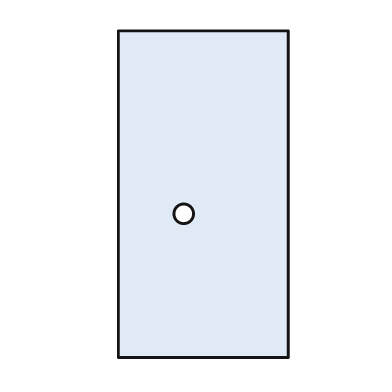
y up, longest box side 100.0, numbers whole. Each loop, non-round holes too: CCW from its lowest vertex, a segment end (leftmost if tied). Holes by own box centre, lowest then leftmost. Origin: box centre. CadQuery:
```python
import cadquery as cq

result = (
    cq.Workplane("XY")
    .moveTo(-26.0, -50.0)
    .lineTo(26.0, -50.0)
    .lineTo(26.0, 50.0)
    .lineTo(-26.0, 50.0)
    .close()
    .moveTo(-6.0, -6.0)
    .circle(3.0)
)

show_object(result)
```